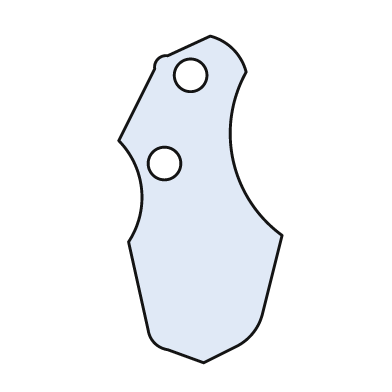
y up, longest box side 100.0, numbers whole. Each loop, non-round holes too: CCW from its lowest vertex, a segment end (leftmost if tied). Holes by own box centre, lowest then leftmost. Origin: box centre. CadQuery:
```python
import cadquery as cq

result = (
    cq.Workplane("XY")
    .moveTo(1.0, -50.0)
    .lineTo(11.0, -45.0)
    .threePointArc((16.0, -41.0), (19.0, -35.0))
    .lineTo(25.0, -11.0)
    .threePointArc((10.0, 12.0), (14.0, 39.0))
    .threePointArc((10.0, 46.0), (3.0, 50.0))
    .lineTo(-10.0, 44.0)
    .threePointArc((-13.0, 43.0), (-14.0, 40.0))
    .lineTo(-25.0, 18.0)
    .threePointArc((-18.0, 3.0), (-22.0, -13.0))
    .lineTo(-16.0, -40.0)
    .threePointArc((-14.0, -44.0), (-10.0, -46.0))
    .close()
    .moveTo(-11.0, 11.0)
    .circle(5.0)
    .moveTo(-3.0, 38.0)
    .circle(5.0)
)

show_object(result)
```